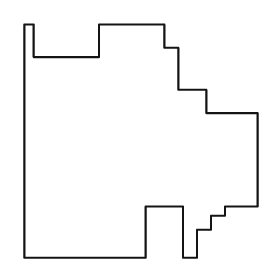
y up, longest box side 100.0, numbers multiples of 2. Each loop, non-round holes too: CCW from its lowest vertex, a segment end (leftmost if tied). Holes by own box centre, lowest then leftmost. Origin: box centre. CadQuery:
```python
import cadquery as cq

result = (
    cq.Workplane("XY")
    .moveTo(-50.0, -50.0)
    .lineTo(2.0, -50.0)
    .lineTo(2.0, -28.0)
    .lineTo(18.0, -28.0)
    .lineTo(18.0, -50.0)
    .lineTo(24.0, -50.0)
    .lineTo(24.0, -38.0)
    .lineTo(30.0, -38.0)
    .lineTo(30.0, -32.0)
    .lineTo(36.0, -32.0)
    .lineTo(36.0, -28.0)
    .lineTo(50.0, -28.0)
    .lineTo(50.0, 12.0)
    .lineTo(28.0, 12.0)
    .lineTo(28.0, 22.0)
    .lineTo(16.0, 22.0)
    .lineTo(16.0, 40.0)
    .lineTo(10.0, 40.0)
    .lineTo(10.0, 50.0)
    .lineTo(-18.0, 50.0)
    .lineTo(-18.0, 36.0)
    .lineTo(-46.0, 36.0)
    .lineTo(-46.0, 50.0)
    .lineTo(-50.0, 50.0)
    .close()
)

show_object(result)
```